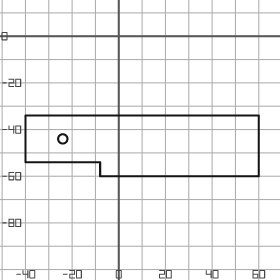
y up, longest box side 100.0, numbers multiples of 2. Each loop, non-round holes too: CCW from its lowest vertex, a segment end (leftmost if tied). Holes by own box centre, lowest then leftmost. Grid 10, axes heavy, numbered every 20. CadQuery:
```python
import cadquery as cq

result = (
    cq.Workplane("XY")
    .moveTo(-8.0, -60.0)
    .lineTo(60.0, -60.0)
    .lineTo(60.0, -34.0)
    .lineTo(-40.0, -34.0)
    .lineTo(-40.0, -54.0)
    .lineTo(-8.0, -54.0)
    .close()
    .moveTo(-24.0, -44.0)
    .circle(2.0)
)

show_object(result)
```